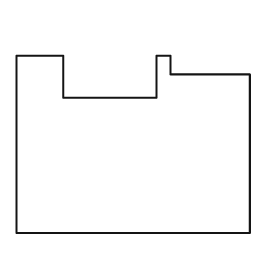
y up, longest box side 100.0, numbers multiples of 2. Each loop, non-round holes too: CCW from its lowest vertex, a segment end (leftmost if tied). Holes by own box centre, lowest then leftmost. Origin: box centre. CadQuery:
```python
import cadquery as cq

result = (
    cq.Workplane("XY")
    .moveTo(-50.0, -38.0)
    .lineTo(50.0, -38.0)
    .lineTo(50.0, 30.0)
    .lineTo(16.0, 30.0)
    .lineTo(16.0, 38.0)
    .lineTo(10.0, 38.0)
    .lineTo(10.0, 20.0)
    .lineTo(-30.0, 20.0)
    .lineTo(-30.0, 38.0)
    .lineTo(-50.0, 38.0)
    .close()
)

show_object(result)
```